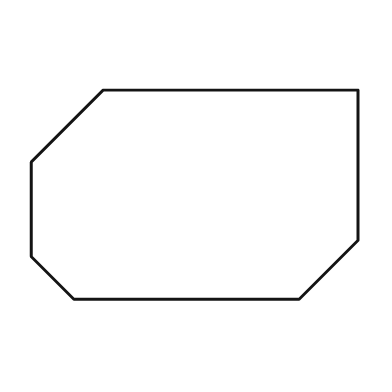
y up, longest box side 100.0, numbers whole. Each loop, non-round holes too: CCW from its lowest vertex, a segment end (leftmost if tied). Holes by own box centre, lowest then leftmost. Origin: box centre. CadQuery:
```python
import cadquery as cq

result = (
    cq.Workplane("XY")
    .moveTo(-37.0, -32.0)
    .lineTo(32.0, -32.0)
    .lineTo(50.0, -14.0)
    .lineTo(50.0, 32.0)
    .lineTo(-28.0, 32.0)
    .lineTo(-50.0, 10.0)
    .lineTo(-50.0, -19.0)
    .close()
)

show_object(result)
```